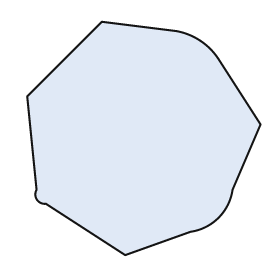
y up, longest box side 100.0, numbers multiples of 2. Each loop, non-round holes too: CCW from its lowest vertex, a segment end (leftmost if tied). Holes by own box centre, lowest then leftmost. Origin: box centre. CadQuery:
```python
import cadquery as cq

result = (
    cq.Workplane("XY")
    .moveTo(-8.0, -50.0)
    .lineTo(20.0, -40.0)
    .threePointArc((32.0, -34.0), (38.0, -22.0))
    .lineTo(50.0, 6.0)
    .lineTo(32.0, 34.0)
    .threePointArc((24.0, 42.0), (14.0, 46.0))
    .lineTo(-18.0, 50.0)
    .lineTo(-50.0, 18.0)
    .lineTo(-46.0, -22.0)
    .threePointArc((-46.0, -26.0), (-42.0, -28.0))
    .close()
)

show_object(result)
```